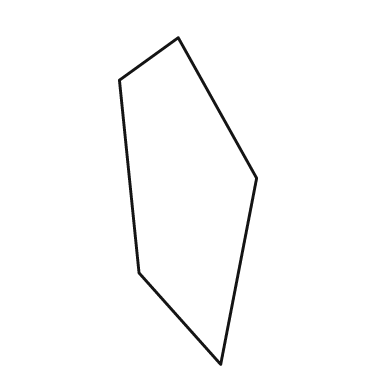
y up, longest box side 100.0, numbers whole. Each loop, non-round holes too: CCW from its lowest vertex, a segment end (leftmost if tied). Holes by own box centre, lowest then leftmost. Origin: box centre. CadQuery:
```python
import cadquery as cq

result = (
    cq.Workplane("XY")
    .moveTo(10.0, -50.0)
    .lineTo(21.0, 7.0)
    .lineTo(-3.0, 50.0)
    .lineTo(-21.0, 37.0)
    .lineTo(-15.0, -22.0)
    .close()
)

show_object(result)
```